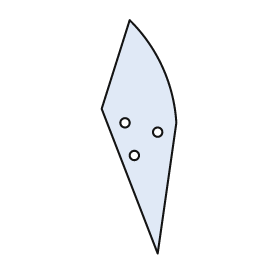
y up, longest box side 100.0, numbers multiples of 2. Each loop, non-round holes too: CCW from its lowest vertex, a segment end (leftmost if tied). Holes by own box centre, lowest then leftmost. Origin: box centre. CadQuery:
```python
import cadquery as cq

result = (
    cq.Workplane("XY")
    .moveTo(8.0, -50.0)
    .lineTo(16.0, 6.0)
    .threePointArc((10.0, 30.0), (-4.0, 50.0))
    .lineTo(-16.0, 12.0)
    .close()
    .moveTo(-2.0, -8.0)
    .circle(2.0)
    .moveTo(8.0, 2.0)
    .circle(2.0)
    .moveTo(-6.0, 6.0)
    .circle(2.0)
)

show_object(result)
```